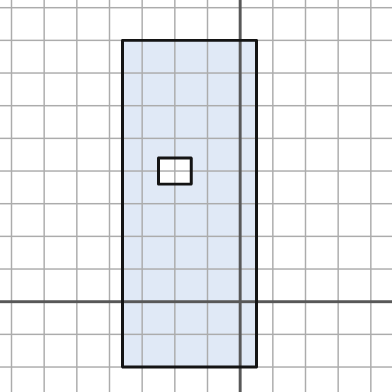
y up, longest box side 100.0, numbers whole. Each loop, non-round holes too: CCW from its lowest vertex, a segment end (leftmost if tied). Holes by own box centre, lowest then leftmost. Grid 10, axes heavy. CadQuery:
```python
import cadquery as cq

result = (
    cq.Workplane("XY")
    .moveTo(-36.0, -20.0)
    .lineTo(5.0, -20.0)
    .lineTo(5.0, 80.0)
    .lineTo(-36.0, 80.0)
    .close()
    .moveTo(-25.0, 36.0)
    .lineTo(-15.0, 36.0)
    .lineTo(-15.0, 44.0)
    .lineTo(-25.0, 44.0)
    .close()
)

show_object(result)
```